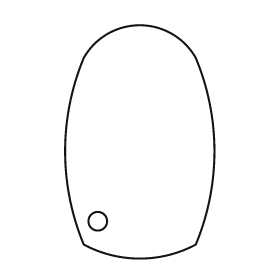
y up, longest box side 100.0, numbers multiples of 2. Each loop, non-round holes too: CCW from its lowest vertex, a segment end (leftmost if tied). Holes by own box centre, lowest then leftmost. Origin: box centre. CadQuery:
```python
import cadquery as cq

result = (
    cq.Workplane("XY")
    .moveTo(-24.0, -44.0)
    .threePointArc((0.0, -50.0), (24.0, -44.0))
    .threePointArc((32.0, -4.0), (24.0, 36.0))
    .threePointArc((0.0, 50.0), (-24.0, 36.0))
    .threePointArc((-32.0, -4.0), (-24.0, -44.0))
    .close()
    .moveTo(-18.0, -34.0)
    .circle(4.0)
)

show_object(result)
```